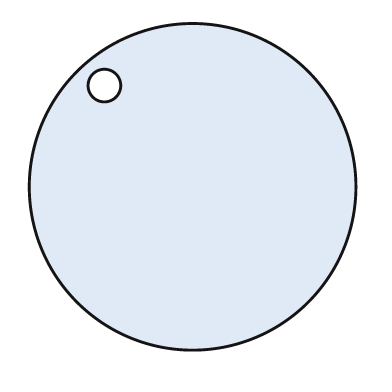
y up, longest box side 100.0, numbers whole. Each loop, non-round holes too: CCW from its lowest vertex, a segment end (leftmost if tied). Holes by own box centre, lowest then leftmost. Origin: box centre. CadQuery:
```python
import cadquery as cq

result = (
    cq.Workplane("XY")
    .moveTo(0.0, 0.0)
    .circle(50.0)
    .moveTo(-27.0, 31.0)
    .circle(5.0)
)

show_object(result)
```